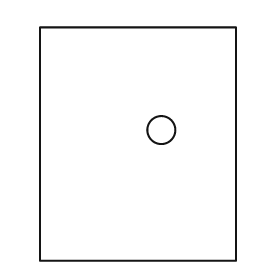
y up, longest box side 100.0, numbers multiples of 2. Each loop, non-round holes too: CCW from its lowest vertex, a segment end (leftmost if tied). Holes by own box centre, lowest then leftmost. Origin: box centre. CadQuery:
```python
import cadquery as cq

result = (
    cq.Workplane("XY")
    .moveTo(-42.0, -50.0)
    .lineTo(42.0, -50.0)
    .lineTo(42.0, 50.0)
    .lineTo(-42.0, 50.0)
    .close()
    .moveTo(10.0, 6.0)
    .circle(6.0)
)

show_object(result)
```